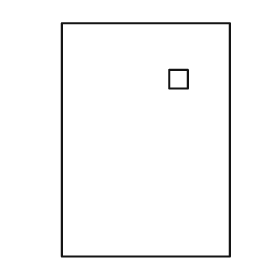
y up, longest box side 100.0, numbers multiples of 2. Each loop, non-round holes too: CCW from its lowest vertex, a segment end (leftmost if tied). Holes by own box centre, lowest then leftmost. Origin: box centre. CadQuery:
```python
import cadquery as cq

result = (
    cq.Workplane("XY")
    .moveTo(-36.0, -50.0)
    .lineTo(36.0, -50.0)
    .lineTo(36.0, 50.0)
    .lineTo(-36.0, 50.0)
    .close()
    .moveTo(10.0, 22.0)
    .lineTo(18.0, 22.0)
    .lineTo(18.0, 30.0)
    .lineTo(10.0, 30.0)
    .close()
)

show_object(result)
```